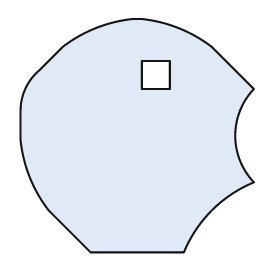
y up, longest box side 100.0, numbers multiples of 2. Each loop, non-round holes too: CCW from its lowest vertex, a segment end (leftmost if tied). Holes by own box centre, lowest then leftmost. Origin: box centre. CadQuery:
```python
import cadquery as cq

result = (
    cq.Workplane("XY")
    .moveTo(-20.0, -50.0)
    .lineTo(20.0, -50.0)
    .threePointArc((32.0, -32.0), (50.0, -20.0))
    .threePointArc((42.0, 0.0), (50.0, 20.0))
    .lineTo(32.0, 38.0)
    .threePointArc((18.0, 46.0), (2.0, 50.0))
    .lineTo(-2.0, 50.0)
    .threePointArc((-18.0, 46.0), (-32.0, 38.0))
    .lineTo(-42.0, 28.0)
    .threePointArc((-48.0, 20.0), (-50.0, 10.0))
    .lineTo(-50.0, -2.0)
    .threePointArc((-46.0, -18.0), (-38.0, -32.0))
    .close()
    .moveTo(2.0, 20.0)
    .lineTo(14.0, 20.0)
    .lineTo(14.0, 32.0)
    .lineTo(2.0, 32.0)
    .close()
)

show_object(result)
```